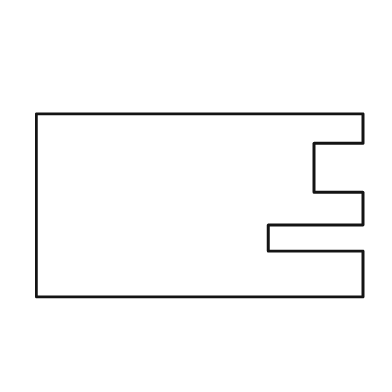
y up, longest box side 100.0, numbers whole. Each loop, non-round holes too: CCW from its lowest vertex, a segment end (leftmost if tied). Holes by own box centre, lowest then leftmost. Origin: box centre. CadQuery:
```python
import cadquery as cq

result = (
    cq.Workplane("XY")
    .moveTo(-50.0, -28.0)
    .lineTo(50.0, -28.0)
    .lineTo(50.0, -14.0)
    .lineTo(21.0, -14.0)
    .lineTo(21.0, -6.0)
    .lineTo(50.0, -6.0)
    .lineTo(50.0, 4.0)
    .lineTo(35.0, 4.0)
    .lineTo(35.0, 19.0)
    .lineTo(50.0, 19.0)
    .lineTo(50.0, 28.0)
    .lineTo(-50.0, 28.0)
    .close()
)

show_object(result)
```